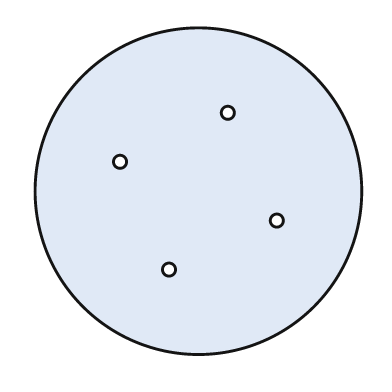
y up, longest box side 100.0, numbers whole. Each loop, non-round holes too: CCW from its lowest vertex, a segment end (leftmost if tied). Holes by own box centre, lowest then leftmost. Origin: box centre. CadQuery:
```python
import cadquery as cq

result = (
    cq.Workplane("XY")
    .moveTo(0.0, 0.0)
    .circle(50.0)
    .moveTo(-9.0, -24.0)
    .circle(2.0)
    .moveTo(24.0, -9.0)
    .circle(2.0)
    .moveTo(-24.0, 9.0)
    .circle(2.0)
    .moveTo(9.0, 24.0)
    .circle(2.0)
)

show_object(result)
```